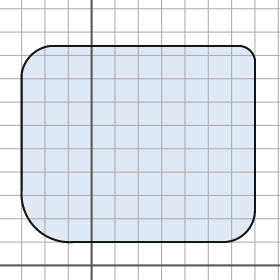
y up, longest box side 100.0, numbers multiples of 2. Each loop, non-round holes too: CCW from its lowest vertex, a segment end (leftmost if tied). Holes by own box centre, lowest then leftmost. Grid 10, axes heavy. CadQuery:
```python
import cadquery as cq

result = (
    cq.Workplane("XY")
    .moveTo(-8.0, 10.0)
    .lineTo(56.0, 10.0)
    .threePointArc((66.0, 14.0), (70.0, 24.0))
    .lineTo(70.0, 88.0)
    .threePointArc((68.0, 92.0), (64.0, 94.0))
    .lineTo(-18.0, 94.0)
    .threePointArc((-26.0, 90.0), (-30.0, 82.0))
    .lineTo(-30.0, 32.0)
    .threePointArc((-24.0, 16.0), (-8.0, 10.0))
    .close()
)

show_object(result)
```